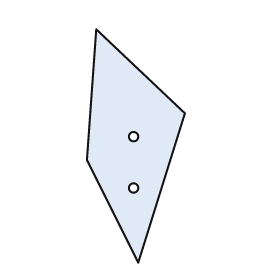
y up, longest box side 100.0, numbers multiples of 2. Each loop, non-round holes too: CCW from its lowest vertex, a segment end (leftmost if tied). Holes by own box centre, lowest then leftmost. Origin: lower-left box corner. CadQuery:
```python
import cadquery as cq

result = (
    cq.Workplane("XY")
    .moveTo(22.0, 0.0)
    .lineTo(42.0, 64.0)
    .lineTo(4.0, 100.0)
    .lineTo(0.0, 44.0)
    .close()
    .moveTo(20.0, 32.0)
    .circle(2.0)
    .moveTo(20.0, 54.0)
    .circle(2.0)
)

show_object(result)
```